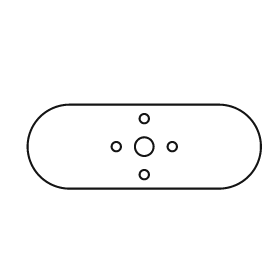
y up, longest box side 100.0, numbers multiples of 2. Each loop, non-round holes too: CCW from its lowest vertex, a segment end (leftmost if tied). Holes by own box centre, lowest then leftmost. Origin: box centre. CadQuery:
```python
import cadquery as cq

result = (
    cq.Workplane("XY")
    .moveTo(-32.0, -18.0)
    .lineTo(32.0, -18.0)
    .threePointArc((50.0, 0.0), (32.0, 18.0))
    .lineTo(-32.0, 18.0)
    .threePointArc((-50.0, 0.0), (-32.0, -18.0))
    .close()
    .moveTo(0.0, -12.0)
    .circle(2.0)
    .moveTo(-12.0, 0.0)
    .circle(2.0)
    .moveTo(0.0, 0.0)
    .circle(4.0)
    .moveTo(12.0, 0.0)
    .circle(2.0)
    .moveTo(0.0, 12.0)
    .circle(2.0)
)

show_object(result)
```